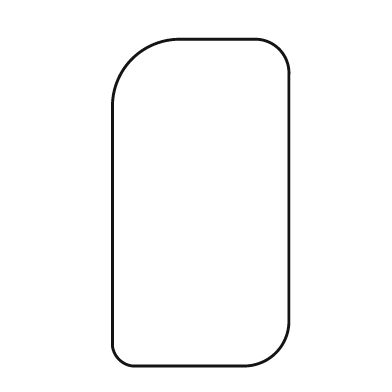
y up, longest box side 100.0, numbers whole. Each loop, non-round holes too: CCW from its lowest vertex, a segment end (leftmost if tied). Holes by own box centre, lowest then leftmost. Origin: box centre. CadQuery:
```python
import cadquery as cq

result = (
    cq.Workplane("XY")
    .moveTo(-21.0, -50.0)
    .lineTo(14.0, -50.0)
    .threePointArc((23.0, -46.0), (27.0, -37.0))
    .lineTo(27.0, 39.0)
    .threePointArc((24.0, 47.0), (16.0, 50.0))
    .lineTo(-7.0, 50.0)
    .threePointArc((-21.0, 44.0), (-27.0, 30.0))
    .lineTo(-27.0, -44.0)
    .threePointArc((-25.0, -48.0), (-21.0, -50.0))
    .close()
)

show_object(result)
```